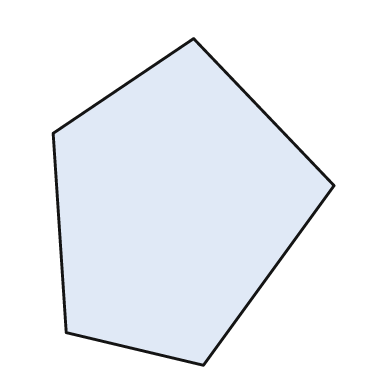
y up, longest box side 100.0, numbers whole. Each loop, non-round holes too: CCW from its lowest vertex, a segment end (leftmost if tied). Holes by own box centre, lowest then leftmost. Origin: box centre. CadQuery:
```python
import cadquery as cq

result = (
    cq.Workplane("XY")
    .moveTo(3.0, -50.0)
    .lineTo(43.0, 5.0)
    .lineTo(0.0, 50.0)
    .lineTo(-43.0, 21.0)
    .lineTo(-39.0, -40.0)
    .close()
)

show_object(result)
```